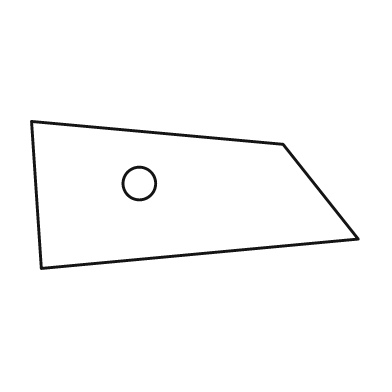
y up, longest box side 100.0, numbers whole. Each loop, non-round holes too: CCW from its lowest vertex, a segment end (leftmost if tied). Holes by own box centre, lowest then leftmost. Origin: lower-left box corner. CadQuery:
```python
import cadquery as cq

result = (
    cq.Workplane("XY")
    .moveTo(3.0, 0.0)
    .lineTo(100.0, 9.0)
    .lineTo(77.0, 38.0)
    .lineTo(0.0, 45.0)
    .close()
    .moveTo(33.0, 26.0)
    .circle(5.0)
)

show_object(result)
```